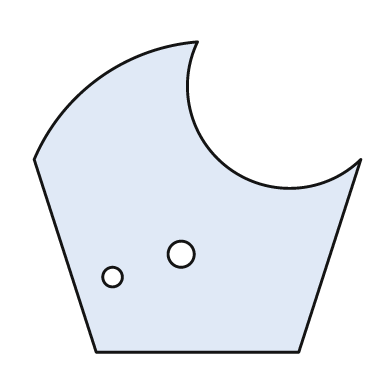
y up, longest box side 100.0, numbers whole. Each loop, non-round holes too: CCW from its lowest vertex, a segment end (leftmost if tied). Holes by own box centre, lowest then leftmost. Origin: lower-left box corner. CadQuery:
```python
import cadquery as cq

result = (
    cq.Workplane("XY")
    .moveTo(19.0, 0.0)
    .lineTo(81.0, 0.0)
    .lineTo(100.0, 59.0)
    .threePointArc((60.0, 56.0), (50.0, 95.0))
    .threePointArc((20.0, 84.0), (0.0, 59.0))
    .close()
    .moveTo(24.0, 23.0)
    .circle(3.0)
    .moveTo(45.0, 30.0)
    .circle(4.0)
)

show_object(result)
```